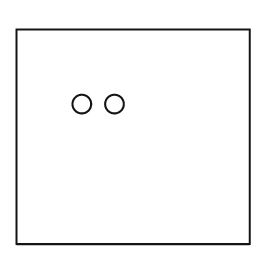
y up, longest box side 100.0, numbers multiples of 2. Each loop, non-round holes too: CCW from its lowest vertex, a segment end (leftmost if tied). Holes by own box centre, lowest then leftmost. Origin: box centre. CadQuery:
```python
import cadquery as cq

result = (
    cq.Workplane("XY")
    .moveTo(-50.0, -46.0)
    .lineTo(50.0, -46.0)
    .lineTo(50.0, 46.0)
    .lineTo(-50.0, 46.0)
    .close()
    .moveTo(-22.0, 14.0)
    .circle(4.0)
    .moveTo(-8.0, 14.0)
    .circle(4.0)
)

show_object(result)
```